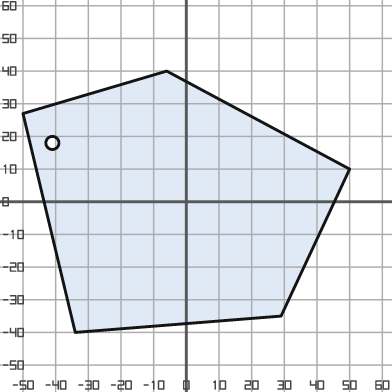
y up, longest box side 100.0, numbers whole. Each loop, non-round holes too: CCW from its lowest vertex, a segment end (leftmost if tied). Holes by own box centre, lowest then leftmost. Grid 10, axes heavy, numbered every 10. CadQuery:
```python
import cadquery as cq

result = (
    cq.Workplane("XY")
    .moveTo(-34.0, -40.0)
    .lineTo(29.0, -35.0)
    .lineTo(50.0, 10.0)
    .lineTo(-6.0, 40.0)
    .lineTo(-50.0, 27.0)
    .close()
    .moveTo(-41.0, 18.0)
    .circle(2.0)
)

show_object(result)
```